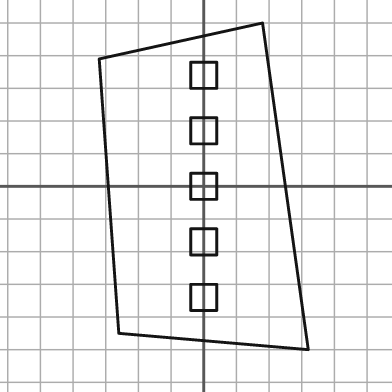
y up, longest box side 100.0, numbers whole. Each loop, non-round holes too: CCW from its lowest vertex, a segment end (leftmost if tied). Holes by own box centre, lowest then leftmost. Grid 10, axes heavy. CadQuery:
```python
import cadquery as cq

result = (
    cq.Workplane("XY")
    .moveTo(32.0, -50.0)
    .lineTo(18.0, 50.0)
    .lineTo(-32.0, 39.0)
    .lineTo(-26.0, -45.0)
    .close()
    .moveTo(-4.0, -38.0)
    .lineTo(4.0, -38.0)
    .lineTo(4.0, -30.0)
    .lineTo(-4.0, -30.0)
    .close()
    .moveTo(-4.0, -21.0)
    .lineTo(4.0, -21.0)
    .lineTo(4.0, -13.0)
    .lineTo(-4.0, -13.0)
    .close()
    .moveTo(-4.0, -4.0)
    .lineTo(4.0, -4.0)
    .lineTo(4.0, 4.0)
    .lineTo(-4.0, 4.0)
    .close()
    .moveTo(-4.0, 13.0)
    .lineTo(4.0, 13.0)
    .lineTo(4.0, 21.0)
    .lineTo(-4.0, 21.0)
    .close()
    .moveTo(-4.0, 30.0)
    .lineTo(4.0, 30.0)
    .lineTo(4.0, 38.0)
    .lineTo(-4.0, 38.0)
    .close()
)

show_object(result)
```